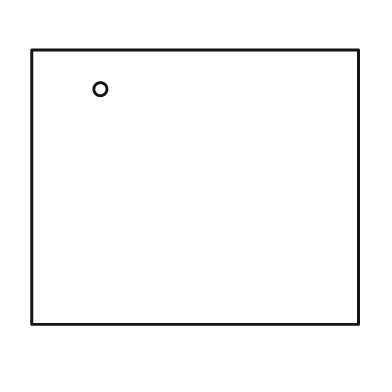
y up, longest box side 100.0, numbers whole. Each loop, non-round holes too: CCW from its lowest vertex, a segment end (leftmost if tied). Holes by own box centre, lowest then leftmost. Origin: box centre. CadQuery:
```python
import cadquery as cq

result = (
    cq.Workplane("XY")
    .moveTo(-50.0, -42.0)
    .lineTo(50.0, -42.0)
    .lineTo(50.0, 42.0)
    .lineTo(-50.0, 42.0)
    .close()
    .moveTo(-29.0, 30.0)
    .circle(2.0)
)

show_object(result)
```